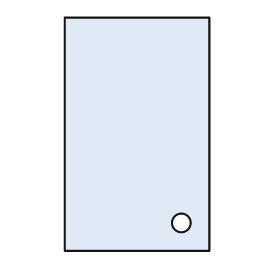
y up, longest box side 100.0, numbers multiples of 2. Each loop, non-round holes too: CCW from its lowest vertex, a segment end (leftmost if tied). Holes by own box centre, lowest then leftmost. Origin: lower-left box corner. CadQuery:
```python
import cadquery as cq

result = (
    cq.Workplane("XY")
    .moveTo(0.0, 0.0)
    .lineTo(62.0, 0.0)
    .lineTo(62.0, 100.0)
    .lineTo(0.0, 100.0)
    .close()
    .moveTo(50.0, 12.0)
    .circle(4.0)
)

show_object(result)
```